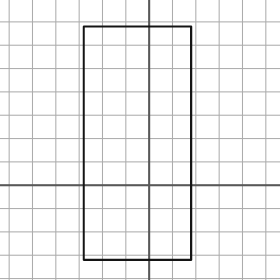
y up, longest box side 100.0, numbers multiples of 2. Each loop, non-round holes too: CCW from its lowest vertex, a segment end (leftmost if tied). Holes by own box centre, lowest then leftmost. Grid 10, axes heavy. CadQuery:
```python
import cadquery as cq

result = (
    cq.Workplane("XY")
    .moveTo(-28.0, -32.0)
    .lineTo(18.0, -32.0)
    .lineTo(18.0, 68.0)
    .lineTo(-28.0, 68.0)
    .close()
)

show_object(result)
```